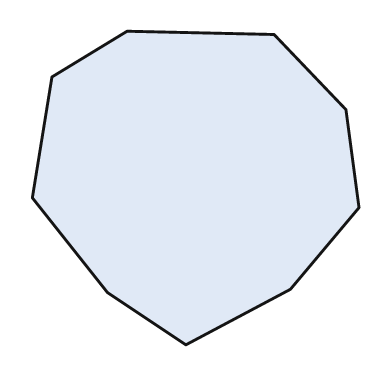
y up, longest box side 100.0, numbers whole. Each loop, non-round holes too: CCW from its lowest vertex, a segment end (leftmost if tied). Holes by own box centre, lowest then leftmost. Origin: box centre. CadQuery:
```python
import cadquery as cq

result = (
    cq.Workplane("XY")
    .moveTo(-3.0, -48.0)
    .lineTo(29.0, -31.0)
    .lineTo(50.0, -6.0)
    .lineTo(46.0, 24.0)
    .lineTo(24.0, 47.0)
    .lineTo(-21.0, 48.0)
    .lineTo(-44.0, 34.0)
    .lineTo(-50.0, -3.0)
    .lineTo(-27.0, -32.0)
    .close()
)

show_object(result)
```